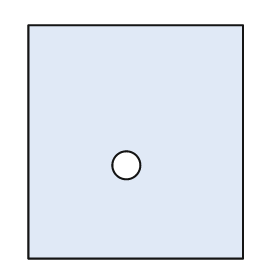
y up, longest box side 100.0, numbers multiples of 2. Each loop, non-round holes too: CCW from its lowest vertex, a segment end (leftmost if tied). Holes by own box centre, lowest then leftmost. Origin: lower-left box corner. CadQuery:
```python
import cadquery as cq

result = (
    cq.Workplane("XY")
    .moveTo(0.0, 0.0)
    .lineTo(92.0, 0.0)
    .lineTo(92.0, 100.0)
    .lineTo(0.0, 100.0)
    .close()
    .moveTo(42.0, 40.0)
    .circle(6.0)
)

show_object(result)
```